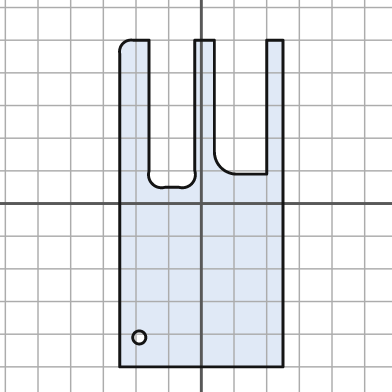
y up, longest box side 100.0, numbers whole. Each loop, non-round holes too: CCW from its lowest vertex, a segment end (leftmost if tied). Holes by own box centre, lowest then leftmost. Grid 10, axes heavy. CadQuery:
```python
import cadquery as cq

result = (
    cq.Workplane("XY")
    .moveTo(-25.0, -50.0)
    .lineTo(25.0, -50.0)
    .lineTo(25.0, 50.0)
    .lineTo(20.0, 50.0)
    .lineTo(20.0, 9.0)
    .lineTo(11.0, 9.0)
    .threePointArc((6.0, 11.0), (4.0, 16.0))
    .lineTo(4.0, 50.0)
    .lineTo(-2.0, 50.0)
    .lineTo(-2.0, 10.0)
    .threePointArc((-3.0, 6.0), (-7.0, 5.0))
    .lineTo(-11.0, 5.0)
    .threePointArc((-15.0, 6.0), (-16.0, 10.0))
    .lineTo(-16.0, 50.0)
    .lineTo(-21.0, 50.0)
    .threePointArc((-24.0, 49.0), (-25.0, 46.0))
    .close()
    .moveTo(-19.0, -41.0)
    .circle(2.0)
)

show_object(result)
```